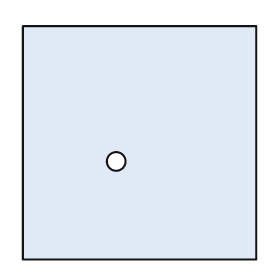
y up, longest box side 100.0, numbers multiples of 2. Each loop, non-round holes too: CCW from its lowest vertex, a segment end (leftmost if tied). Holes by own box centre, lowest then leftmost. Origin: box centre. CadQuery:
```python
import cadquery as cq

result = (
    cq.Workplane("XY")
    .moveTo(-50.0, -50.0)
    .lineTo(50.0, -50.0)
    .lineTo(50.0, 50.0)
    .lineTo(-50.0, 50.0)
    .close()
    .moveTo(-10.0, -8.0)
    .circle(4.0)
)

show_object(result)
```